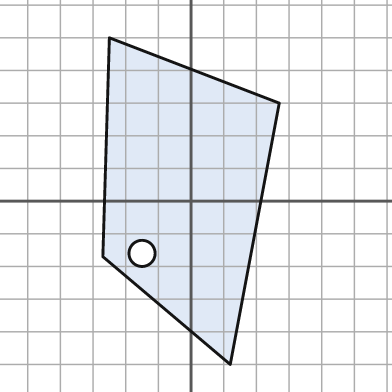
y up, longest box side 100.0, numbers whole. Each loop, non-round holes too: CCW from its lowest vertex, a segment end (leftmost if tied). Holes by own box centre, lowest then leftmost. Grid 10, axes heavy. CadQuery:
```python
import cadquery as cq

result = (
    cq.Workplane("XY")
    .moveTo(12.0, -50.0)
    .lineTo(27.0, 30.0)
    .lineTo(-25.0, 50.0)
    .lineTo(-27.0, -17.0)
    .close()
    .moveTo(-15.0, -16.0)
    .circle(4.0)
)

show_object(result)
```